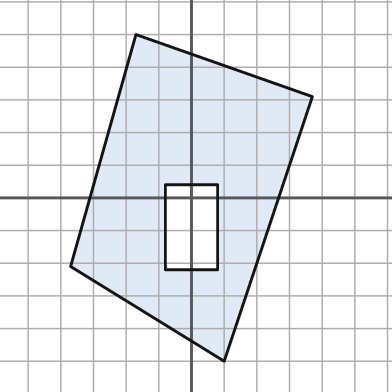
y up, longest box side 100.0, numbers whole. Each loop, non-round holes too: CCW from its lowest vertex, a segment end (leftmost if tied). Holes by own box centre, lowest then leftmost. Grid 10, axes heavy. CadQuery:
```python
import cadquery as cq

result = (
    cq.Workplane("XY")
    .moveTo(10.0, -50.0)
    .lineTo(37.0, 31.0)
    .lineTo(-17.0, 50.0)
    .lineTo(-37.0, -21.0)
    .close()
    .moveTo(-8.0, -22.0)
    .lineTo(8.0, -22.0)
    .lineTo(8.0, 4.0)
    .lineTo(-8.0, 4.0)
    .close()
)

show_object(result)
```